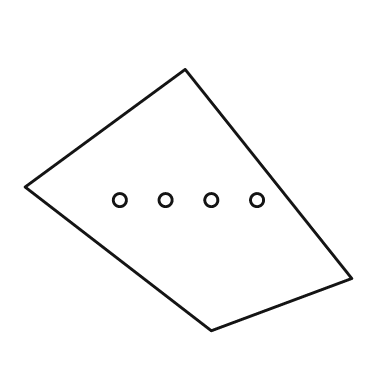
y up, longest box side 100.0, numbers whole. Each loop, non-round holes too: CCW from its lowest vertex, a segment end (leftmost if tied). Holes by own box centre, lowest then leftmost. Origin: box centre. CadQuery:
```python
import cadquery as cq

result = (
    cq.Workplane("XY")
    .moveTo(7.0, -40.0)
    .lineTo(50.0, -24.0)
    .lineTo(-1.0, 40.0)
    .lineTo(-50.0, 4.0)
    .close()
    .moveTo(-21.0, 0.0)
    .circle(2.0)
    .moveTo(-7.0, 0.0)
    .circle(2.0)
    .moveTo(7.0, 0.0)
    .circle(2.0)
    .moveTo(21.0, 0.0)
    .circle(2.0)
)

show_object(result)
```